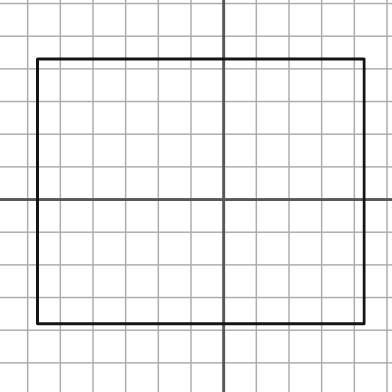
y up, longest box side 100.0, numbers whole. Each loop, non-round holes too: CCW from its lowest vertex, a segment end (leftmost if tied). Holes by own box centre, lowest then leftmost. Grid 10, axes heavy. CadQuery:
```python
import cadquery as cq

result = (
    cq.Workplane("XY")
    .moveTo(-57.0, -38.0)
    .lineTo(43.0, -38.0)
    .lineTo(43.0, 43.0)
    .lineTo(-57.0, 43.0)
    .close()
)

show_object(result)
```